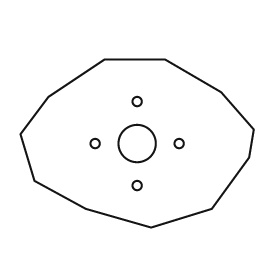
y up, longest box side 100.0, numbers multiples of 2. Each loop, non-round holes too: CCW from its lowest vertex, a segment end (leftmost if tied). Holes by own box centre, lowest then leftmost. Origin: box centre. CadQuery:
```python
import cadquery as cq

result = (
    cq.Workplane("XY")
    .moveTo(6.0, -36.0)
    .lineTo(32.0, -28.0)
    .lineTo(48.0, -6.0)
    .lineTo(50.0, 6.0)
    .lineTo(36.0, 22.0)
    .lineTo(12.0, 36.0)
    .lineTo(-14.0, 36.0)
    .lineTo(-38.0, 20.0)
    .lineTo(-50.0, 4.0)
    .lineTo(-44.0, -16.0)
    .lineTo(-22.0, -28.0)
    .close()
    .moveTo(0.0, -18.0)
    .circle(2.0)
    .moveTo(-18.0, 0.0)
    .circle(2.0)
    .moveTo(0.0, 0.0)
    .circle(8.0)
    .moveTo(18.0, 0.0)
    .circle(2.0)
    .moveTo(0.0, 18.0)
    .circle(2.0)
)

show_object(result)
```